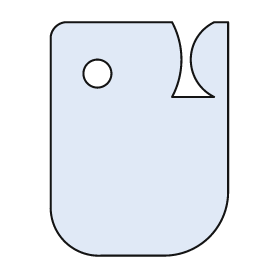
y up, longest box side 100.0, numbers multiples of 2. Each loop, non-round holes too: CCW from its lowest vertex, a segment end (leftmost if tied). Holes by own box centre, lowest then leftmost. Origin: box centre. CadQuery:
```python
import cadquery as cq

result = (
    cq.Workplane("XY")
    .moveTo(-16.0, -50.0)
    .lineTo(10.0, -50.0)
    .threePointArc((30.0, -42.0), (38.0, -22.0))
    .lineTo(38.0, 50.0)
    .lineTo(32.0, 50.0)
    .threePointArc((22.0, 34.0), (32.0, 18.0))
    .lineTo(14.0, 18.0)
    .threePointArc((18.0, 34.0), (14.0, 50.0))
    .lineTo(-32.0, 50.0)
    .threePointArc((-36.0, 48.0), (-38.0, 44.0))
    .lineTo(-38.0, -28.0)
    .threePointArc((-32.0, -44.0), (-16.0, -50.0))
    .close()
    .moveTo(-18.0, 28.0)
    .circle(6.0)
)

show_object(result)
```